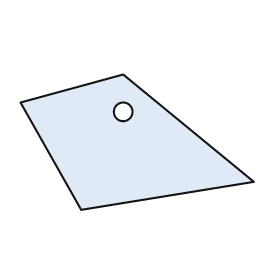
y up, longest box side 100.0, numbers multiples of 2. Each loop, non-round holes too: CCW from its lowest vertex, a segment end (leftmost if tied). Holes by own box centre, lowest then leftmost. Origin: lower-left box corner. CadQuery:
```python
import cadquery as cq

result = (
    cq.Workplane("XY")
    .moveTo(26.0, 0.0)
    .lineTo(100.0, 12.0)
    .lineTo(44.0, 58.0)
    .lineTo(0.0, 46.0)
    .close()
    .moveTo(44.0, 42.0)
    .circle(4.0)
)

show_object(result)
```